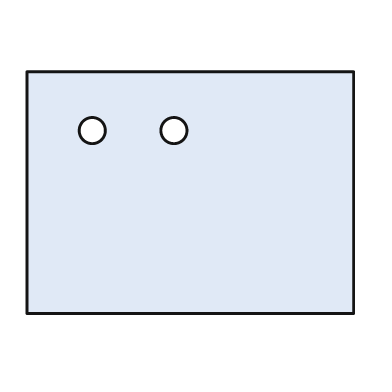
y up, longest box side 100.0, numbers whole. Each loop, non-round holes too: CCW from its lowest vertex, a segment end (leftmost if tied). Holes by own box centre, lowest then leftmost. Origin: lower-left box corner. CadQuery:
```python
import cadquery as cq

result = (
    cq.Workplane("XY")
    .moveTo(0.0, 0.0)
    .lineTo(100.0, 0.0)
    .lineTo(100.0, 74.0)
    .lineTo(0.0, 74.0)
    .close()
    .moveTo(20.0, 56.0)
    .circle(4.0)
    .moveTo(45.0, 56.0)
    .circle(4.0)
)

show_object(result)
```